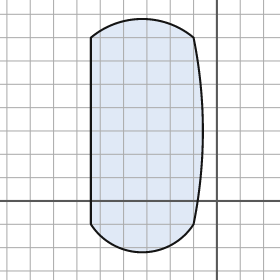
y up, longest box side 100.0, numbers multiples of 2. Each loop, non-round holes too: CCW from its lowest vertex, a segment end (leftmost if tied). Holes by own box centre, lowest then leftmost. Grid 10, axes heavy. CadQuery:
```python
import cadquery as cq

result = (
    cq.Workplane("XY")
    .moveTo(-54.0, -10.0)
    .threePointArc((-32.0, -22.0), (-10.0, -10.0))
    .threePointArc((-6.0, 30.0), (-10.0, 70.0))
    .threePointArc((-32.0, 78.0), (-54.0, 70.0))
    .close()
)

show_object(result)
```